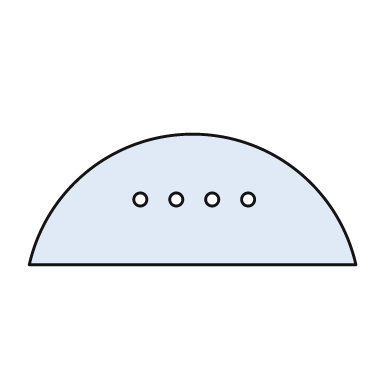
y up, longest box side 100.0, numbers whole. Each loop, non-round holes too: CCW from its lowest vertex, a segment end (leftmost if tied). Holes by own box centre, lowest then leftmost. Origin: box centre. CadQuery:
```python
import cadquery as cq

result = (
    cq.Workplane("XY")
    .moveTo(-50.0, -20.0)
    .lineTo(50.0, -20.0)
    .threePointArc((0.0, 20.0), (-50.0, -20.0))
    .close()
    .moveTo(-16.0, 0.0)
    .circle(2.0)
    .moveTo(-5.0, 0.0)
    .circle(2.0)
    .moveTo(6.0, 0.0)
    .circle(2.0)
    .moveTo(17.0, 0.0)
    .circle(2.0)
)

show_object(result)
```